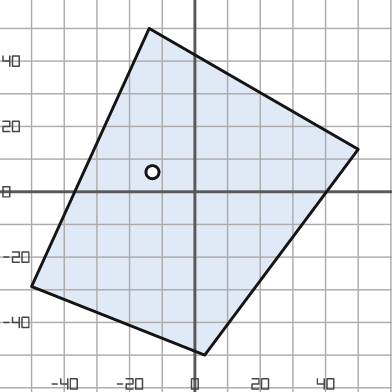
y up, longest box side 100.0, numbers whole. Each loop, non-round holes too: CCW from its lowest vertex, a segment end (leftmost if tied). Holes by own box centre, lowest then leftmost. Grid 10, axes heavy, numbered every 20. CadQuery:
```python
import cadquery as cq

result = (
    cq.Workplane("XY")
    .moveTo(3.0, -50.0)
    .lineTo(50.0, 13.0)
    .lineTo(-14.0, 50.0)
    .lineTo(-50.0, -29.0)
    .close()
    .moveTo(-13.0, 6.0)
    .circle(2.0)
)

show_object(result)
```